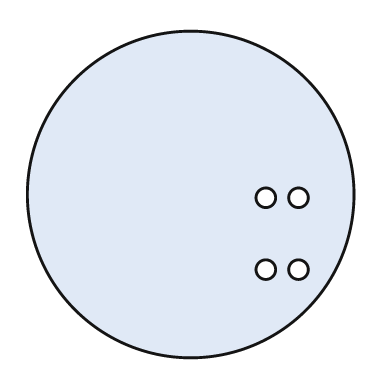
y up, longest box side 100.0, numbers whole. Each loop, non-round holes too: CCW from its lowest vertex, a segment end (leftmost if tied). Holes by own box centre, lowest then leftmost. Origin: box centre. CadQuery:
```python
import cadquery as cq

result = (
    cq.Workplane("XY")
    .moveTo(0.0, 0.0)
    .circle(50.0)
    .moveTo(23.0, -23.0)
    .circle(3.0)
    .moveTo(33.0, -23.0)
    .circle(3.0)
    .moveTo(23.0, -1.0)
    .circle(3.0)
    .moveTo(33.0, -1.0)
    .circle(3.0)
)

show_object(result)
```